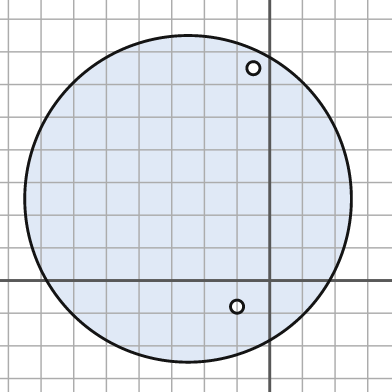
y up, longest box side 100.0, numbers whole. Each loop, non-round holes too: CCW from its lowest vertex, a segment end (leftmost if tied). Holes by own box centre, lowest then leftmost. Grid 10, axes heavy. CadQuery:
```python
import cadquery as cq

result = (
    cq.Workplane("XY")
    .moveTo(-25.0, 25.0)
    .circle(50.0)
    .moveTo(-10.0, -8.0)
    .circle(2.0)
    .moveTo(-5.0, 65.0)
    .circle(2.0)
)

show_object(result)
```